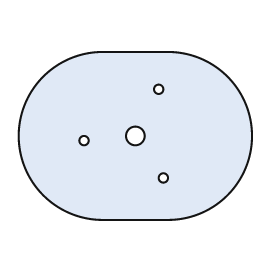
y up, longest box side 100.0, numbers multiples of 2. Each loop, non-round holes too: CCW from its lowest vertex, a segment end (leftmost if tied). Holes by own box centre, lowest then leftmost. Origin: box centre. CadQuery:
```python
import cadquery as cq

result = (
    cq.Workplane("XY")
    .moveTo(-14.0, -36.0)
    .lineTo(14.0, -36.0)
    .threePointArc((50.0, 0.0), (14.0, 36.0))
    .lineTo(-14.0, 36.0)
    .threePointArc((-50.0, 0.0), (-14.0, -36.0))
    .close()
    .moveTo(12.0, -18.0)
    .circle(2.0)
    .moveTo(-22.0, -2.0)
    .circle(2.0)
    .moveTo(0.0, 0.0)
    .circle(4.0)
    .moveTo(10.0, 20.0)
    .circle(2.0)
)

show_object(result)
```